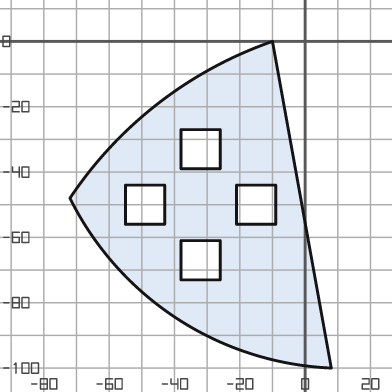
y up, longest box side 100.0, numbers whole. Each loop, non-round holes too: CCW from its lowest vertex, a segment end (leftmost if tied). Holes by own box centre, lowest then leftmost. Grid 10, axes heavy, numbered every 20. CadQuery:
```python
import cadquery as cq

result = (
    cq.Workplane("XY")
    .moveTo(8.0, -100.0)
    .lineTo(-10.0, 0.0)
    .threePointArc((-45.0, -19.0), (-72.0, -48.0))
    .threePointArc((-39.0, -85.0), (8.0, -100.0))
    .close()
    .moveTo(-38.0, -73.0)
    .lineTo(-26.0, -73.0)
    .lineTo(-26.0, -61.0)
    .lineTo(-38.0, -61.0)
    .close()
    .moveTo(-55.0, -56.0)
    .lineTo(-43.0, -56.0)
    .lineTo(-43.0, -44.0)
    .lineTo(-55.0, -44.0)
    .close()
    .moveTo(-21.0, -56.0)
    .lineTo(-9.0, -56.0)
    .lineTo(-9.0, -44.0)
    .lineTo(-21.0, -44.0)
    .close()
    .moveTo(-38.0, -39.0)
    .lineTo(-26.0, -39.0)
    .lineTo(-26.0, -27.0)
    .lineTo(-38.0, -27.0)
    .close()
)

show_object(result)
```